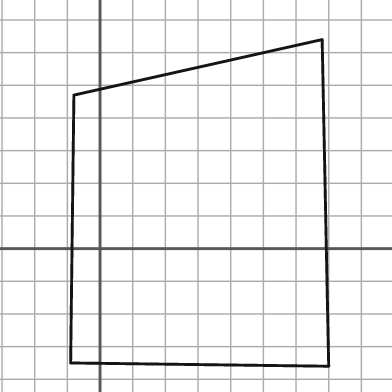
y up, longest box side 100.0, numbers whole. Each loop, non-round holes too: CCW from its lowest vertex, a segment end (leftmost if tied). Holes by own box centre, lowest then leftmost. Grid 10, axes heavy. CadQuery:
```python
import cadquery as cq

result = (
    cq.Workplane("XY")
    .moveTo(70.0, -36.0)
    .lineTo(68.0, 64.0)
    .lineTo(-8.0, 47.0)
    .lineTo(-9.0, -35.0)
    .close()
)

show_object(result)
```